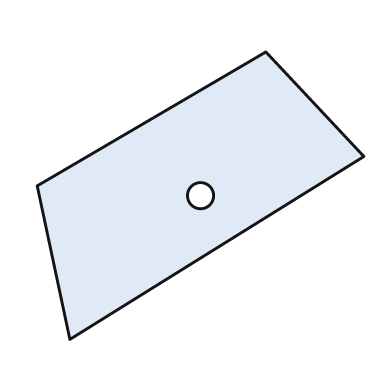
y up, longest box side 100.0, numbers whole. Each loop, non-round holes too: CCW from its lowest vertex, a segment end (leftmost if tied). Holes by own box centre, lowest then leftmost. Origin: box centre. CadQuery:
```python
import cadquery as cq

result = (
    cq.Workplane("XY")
    .moveTo(-40.0, -44.0)
    .lineTo(50.0, 12.0)
    .lineTo(20.0, 44.0)
    .lineTo(-50.0, 3.0)
    .close()
    .moveTo(0.0, 0.0)
    .circle(4.0)
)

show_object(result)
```